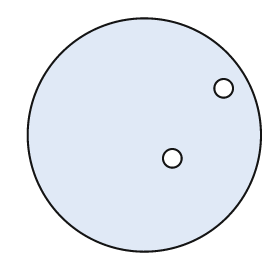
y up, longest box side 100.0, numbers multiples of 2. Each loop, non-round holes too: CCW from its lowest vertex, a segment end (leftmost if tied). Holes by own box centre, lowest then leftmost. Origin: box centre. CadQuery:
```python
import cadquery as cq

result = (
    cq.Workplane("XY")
    .moveTo(0.0, 0.0)
    .circle(50.0)
    .moveTo(12.0, -10.0)
    .circle(4.0)
    .moveTo(34.0, 20.0)
    .circle(4.0)
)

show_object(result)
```